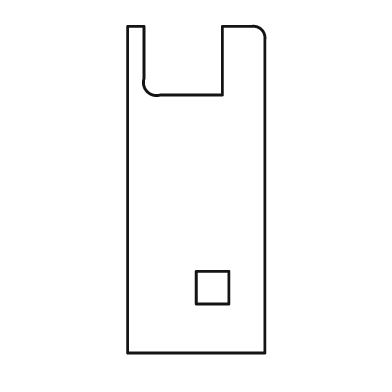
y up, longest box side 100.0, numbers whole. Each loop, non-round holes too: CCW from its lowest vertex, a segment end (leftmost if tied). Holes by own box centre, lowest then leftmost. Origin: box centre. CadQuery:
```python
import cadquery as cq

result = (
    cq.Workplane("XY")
    .moveTo(-21.0, -50.0)
    .lineTo(21.0, -50.0)
    .lineTo(21.0, 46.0)
    .threePointArc((20.0, 49.0), (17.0, 50.0))
    .lineTo(8.0, 50.0)
    .lineTo(8.0, 29.0)
    .lineTo(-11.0, 29.0)
    .threePointArc((-15.0, 30.0), (-16.0, 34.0))
    .lineTo(-16.0, 50.0)
    .lineTo(-21.0, 50.0)
    .close()
    .moveTo(0.0, -35.0)
    .lineTo(10.0, -35.0)
    .lineTo(10.0, -25.0)
    .lineTo(0.0, -25.0)
    .close()
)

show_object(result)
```